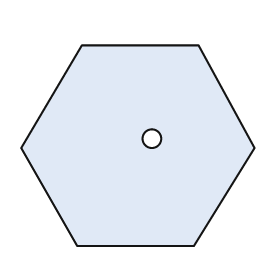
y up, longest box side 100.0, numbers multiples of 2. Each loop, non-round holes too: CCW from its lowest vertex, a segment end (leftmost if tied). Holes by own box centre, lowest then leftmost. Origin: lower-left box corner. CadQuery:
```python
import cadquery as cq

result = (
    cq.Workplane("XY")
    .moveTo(24.0, 0.0)
    .lineTo(74.0, 0.0)
    .lineTo(100.0, 42.0)
    .lineTo(76.0, 86.0)
    .lineTo(26.0, 86.0)
    .lineTo(0.0, 42.0)
    .close()
    .moveTo(56.0, 46.0)
    .circle(4.0)
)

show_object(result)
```